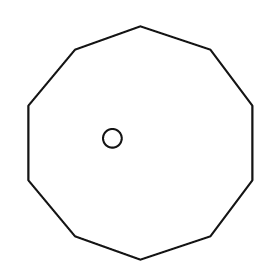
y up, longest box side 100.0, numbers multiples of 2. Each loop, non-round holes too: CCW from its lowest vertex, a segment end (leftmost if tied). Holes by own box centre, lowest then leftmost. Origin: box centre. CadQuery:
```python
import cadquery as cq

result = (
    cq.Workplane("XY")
    .moveTo(0.0, -50.0)
    .lineTo(30.0, -40.0)
    .lineTo(48.0, -16.0)
    .lineTo(48.0, 16.0)
    .lineTo(30.0, 40.0)
    .lineTo(0.0, 50.0)
    .lineTo(-28.0, 40.0)
    .lineTo(-48.0, 16.0)
    .lineTo(-48.0, -16.0)
    .lineTo(-28.0, -40.0)
    .close()
    .moveTo(-12.0, 2.0)
    .circle(4.0)
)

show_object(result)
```